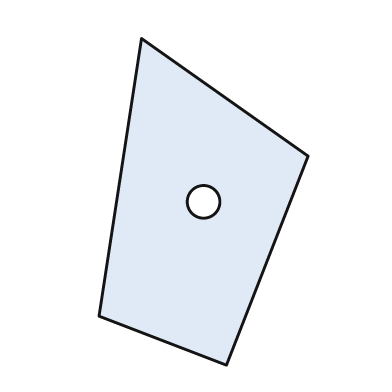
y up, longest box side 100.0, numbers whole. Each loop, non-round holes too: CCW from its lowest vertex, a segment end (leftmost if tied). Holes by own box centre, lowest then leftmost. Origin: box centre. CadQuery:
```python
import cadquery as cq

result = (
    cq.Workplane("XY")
    .moveTo(7.0, -50.0)
    .lineTo(32.0, 14.0)
    .lineTo(-19.0, 50.0)
    .lineTo(-32.0, -35.0)
    .close()
    .moveTo(0.0, 0.0)
    .circle(5.0)
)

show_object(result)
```